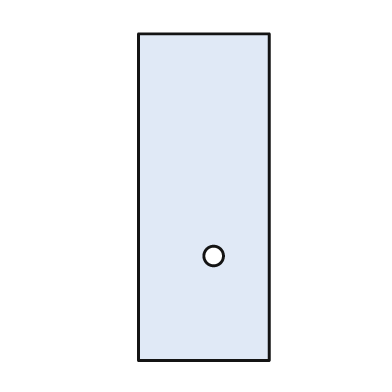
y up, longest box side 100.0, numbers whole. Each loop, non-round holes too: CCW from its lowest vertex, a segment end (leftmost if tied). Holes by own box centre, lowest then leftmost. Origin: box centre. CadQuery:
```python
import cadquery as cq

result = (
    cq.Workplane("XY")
    .moveTo(-20.0, -50.0)
    .lineTo(20.0, -50.0)
    .lineTo(20.0, 50.0)
    .lineTo(-20.0, 50.0)
    .close()
    .moveTo(3.0, -18.0)
    .circle(3.0)
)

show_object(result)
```